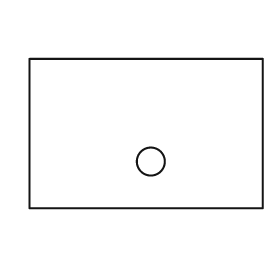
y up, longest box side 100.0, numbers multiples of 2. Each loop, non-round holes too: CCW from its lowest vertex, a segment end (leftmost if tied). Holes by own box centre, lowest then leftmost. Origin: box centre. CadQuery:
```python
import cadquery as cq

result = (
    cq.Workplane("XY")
    .moveTo(-50.0, -32.0)
    .lineTo(50.0, -32.0)
    .lineTo(50.0, 32.0)
    .lineTo(-50.0, 32.0)
    .close()
    .moveTo(2.0, -12.0)
    .circle(6.0)
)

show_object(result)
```